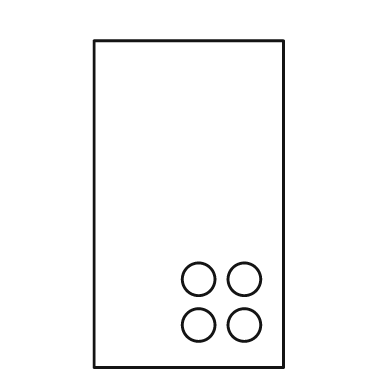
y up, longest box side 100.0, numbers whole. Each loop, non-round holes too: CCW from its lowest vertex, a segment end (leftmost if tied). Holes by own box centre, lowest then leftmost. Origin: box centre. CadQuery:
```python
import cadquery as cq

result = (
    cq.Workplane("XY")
    .moveTo(-29.0, -50.0)
    .lineTo(29.0, -50.0)
    .lineTo(29.0, 50.0)
    .lineTo(-29.0, 50.0)
    .close()
    .moveTo(3.0, -37.0)
    .circle(5.0)
    .moveTo(17.0, -37.0)
    .circle(5.0)
    .moveTo(3.0, -23.0)
    .circle(5.0)
    .moveTo(17.0, -23.0)
    .circle(5.0)
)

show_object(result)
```